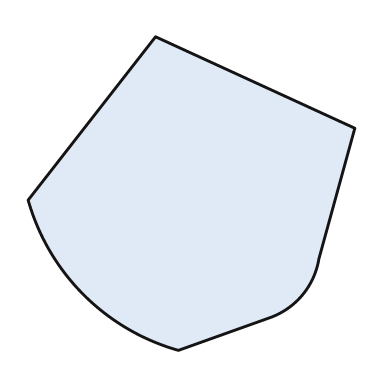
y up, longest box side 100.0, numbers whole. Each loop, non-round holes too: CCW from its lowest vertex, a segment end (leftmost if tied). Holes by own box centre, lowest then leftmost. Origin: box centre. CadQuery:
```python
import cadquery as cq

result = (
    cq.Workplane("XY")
    .moveTo(-4.0, -48.0)
    .lineTo(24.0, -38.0)
    .threePointArc((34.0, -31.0), (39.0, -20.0))
    .lineTo(50.0, 20.0)
    .lineTo(-11.0, 48.0)
    .lineTo(-50.0, -2.0)
    .threePointArc((-33.0, -31.0), (-4.0, -48.0))
    .close()
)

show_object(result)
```